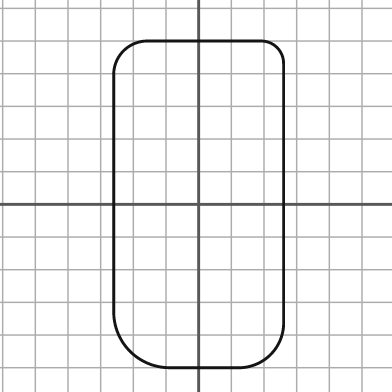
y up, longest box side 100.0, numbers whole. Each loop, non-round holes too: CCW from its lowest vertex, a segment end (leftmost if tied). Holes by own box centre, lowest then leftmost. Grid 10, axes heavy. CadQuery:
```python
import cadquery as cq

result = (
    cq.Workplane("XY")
    .moveTo(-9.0, -50.0)
    .lineTo(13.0, -50.0)
    .threePointArc((22.0, -46.0), (26.0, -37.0))
    .lineTo(26.0, 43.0)
    .threePointArc((24.0, 48.0), (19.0, 50.0))
    .lineTo(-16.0, 50.0)
    .threePointArc((-23.0, 47.0), (-26.0, 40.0))
    .lineTo(-26.0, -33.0)
    .threePointArc((-21.0, -45.0), (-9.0, -50.0))
    .close()
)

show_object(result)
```